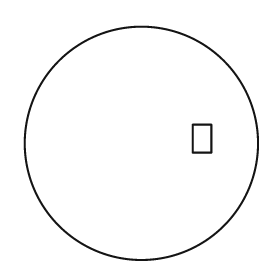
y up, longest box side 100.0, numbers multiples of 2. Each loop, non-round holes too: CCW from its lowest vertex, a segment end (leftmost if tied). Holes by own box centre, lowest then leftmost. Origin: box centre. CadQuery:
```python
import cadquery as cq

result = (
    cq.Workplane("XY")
    .moveTo(0.0, 0.0)
    .circle(50.0)
    .moveTo(22.0, -4.0)
    .lineTo(30.0, -4.0)
    .lineTo(30.0, 8.0)
    .lineTo(22.0, 8.0)
    .close()
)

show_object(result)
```